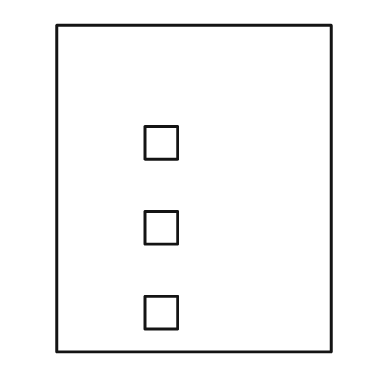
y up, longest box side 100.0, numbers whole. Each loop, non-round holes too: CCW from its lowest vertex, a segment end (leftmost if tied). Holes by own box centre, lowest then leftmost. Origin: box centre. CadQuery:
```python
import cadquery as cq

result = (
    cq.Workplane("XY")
    .moveTo(-42.0, -50.0)
    .lineTo(42.0, -50.0)
    .lineTo(42.0, 50.0)
    .lineTo(-42.0, 50.0)
    .close()
    .moveTo(-15.0, -43.0)
    .lineTo(-5.0, -43.0)
    .lineTo(-5.0, -33.0)
    .lineTo(-15.0, -33.0)
    .close()
    .moveTo(-15.0, -17.0)
    .lineTo(-5.0, -17.0)
    .lineTo(-5.0, -7.0)
    .lineTo(-15.0, -7.0)
    .close()
    .moveTo(-15.0, 9.0)
    .lineTo(-5.0, 9.0)
    .lineTo(-5.0, 19.0)
    .lineTo(-15.0, 19.0)
    .close()
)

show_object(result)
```